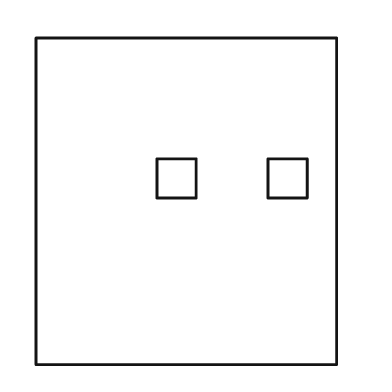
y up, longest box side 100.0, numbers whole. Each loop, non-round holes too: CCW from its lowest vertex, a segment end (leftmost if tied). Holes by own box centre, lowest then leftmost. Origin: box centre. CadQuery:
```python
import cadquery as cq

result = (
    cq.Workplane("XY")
    .moveTo(-46.0, -50.0)
    .lineTo(46.0, -50.0)
    .lineTo(46.0, 50.0)
    .lineTo(-46.0, 50.0)
    .close()
    .moveTo(-9.0, 1.0)
    .lineTo(3.0, 1.0)
    .lineTo(3.0, 13.0)
    .lineTo(-9.0, 13.0)
    .close()
    .moveTo(25.0, 1.0)
    .lineTo(37.0, 1.0)
    .lineTo(37.0, 13.0)
    .lineTo(25.0, 13.0)
    .close()
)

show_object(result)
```